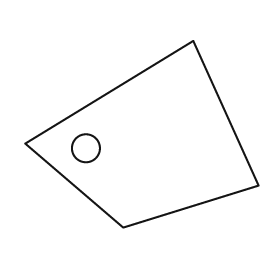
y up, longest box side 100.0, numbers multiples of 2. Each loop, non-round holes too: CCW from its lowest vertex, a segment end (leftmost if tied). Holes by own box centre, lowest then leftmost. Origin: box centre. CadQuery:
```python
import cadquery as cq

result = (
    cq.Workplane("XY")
    .moveTo(-8.0, -40.0)
    .lineTo(50.0, -22.0)
    .lineTo(22.0, 40.0)
    .lineTo(-50.0, -4.0)
    .close()
    .moveTo(-24.0, -6.0)
    .circle(6.0)
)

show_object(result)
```